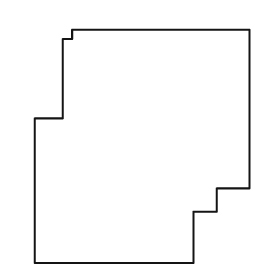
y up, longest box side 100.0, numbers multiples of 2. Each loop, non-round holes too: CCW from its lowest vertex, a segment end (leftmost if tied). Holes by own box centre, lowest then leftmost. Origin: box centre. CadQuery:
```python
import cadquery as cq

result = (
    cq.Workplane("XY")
    .moveTo(-46.0, -50.0)
    .lineTo(22.0, -50.0)
    .lineTo(22.0, -28.0)
    .lineTo(32.0, -28.0)
    .lineTo(32.0, -18.0)
    .lineTo(46.0, -18.0)
    .lineTo(46.0, 50.0)
    .lineTo(-30.0, 50.0)
    .lineTo(-30.0, 46.0)
    .lineTo(-34.0, 46.0)
    .lineTo(-34.0, 12.0)
    .lineTo(-46.0, 12.0)
    .close()
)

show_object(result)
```